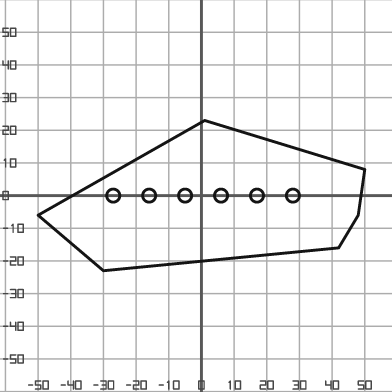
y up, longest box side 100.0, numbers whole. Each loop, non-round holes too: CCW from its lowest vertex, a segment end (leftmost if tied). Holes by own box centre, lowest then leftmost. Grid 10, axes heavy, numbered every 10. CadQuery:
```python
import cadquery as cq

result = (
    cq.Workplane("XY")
    .moveTo(-30.0, -23.0)
    .lineTo(42.0, -16.0)
    .lineTo(48.0, -6.0)
    .lineTo(50.0, 8.0)
    .lineTo(1.0, 23.0)
    .lineTo(-50.0, -6.0)
    .close()
    .moveTo(-27.0, 0.0)
    .circle(2.0)
    .moveTo(-16.0, 0.0)
    .circle(2.0)
    .moveTo(-5.0, 0.0)
    .circle(2.0)
    .moveTo(6.0, 0.0)
    .circle(2.0)
    .moveTo(17.0, 0.0)
    .circle(2.0)
    .moveTo(28.0, 0.0)
    .circle(2.0)
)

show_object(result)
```